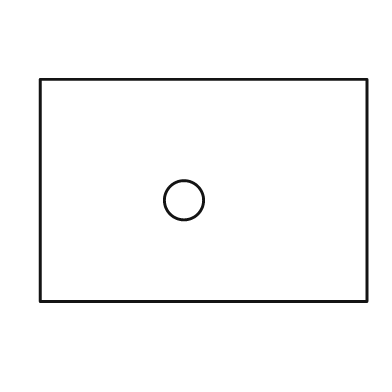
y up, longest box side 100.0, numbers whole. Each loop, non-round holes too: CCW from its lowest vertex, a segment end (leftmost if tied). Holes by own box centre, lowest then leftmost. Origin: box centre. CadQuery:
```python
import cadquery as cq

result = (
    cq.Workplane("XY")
    .moveTo(-50.0, -34.0)
    .lineTo(50.0, -34.0)
    .lineTo(50.0, 34.0)
    .lineTo(-50.0, 34.0)
    .close()
    .moveTo(-6.0, -3.0)
    .circle(6.0)
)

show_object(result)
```